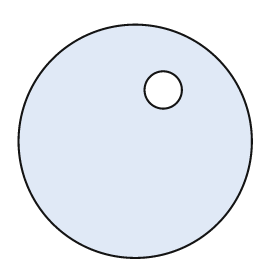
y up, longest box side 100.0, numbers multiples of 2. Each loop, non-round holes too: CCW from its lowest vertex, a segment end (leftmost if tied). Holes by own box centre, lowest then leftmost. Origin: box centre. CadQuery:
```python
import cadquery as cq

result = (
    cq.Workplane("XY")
    .moveTo(0.0, 0.0)
    .circle(50.0)
    .moveTo(12.0, 22.0)
    .circle(8.0)
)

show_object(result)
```